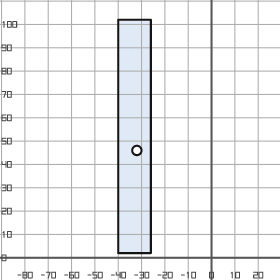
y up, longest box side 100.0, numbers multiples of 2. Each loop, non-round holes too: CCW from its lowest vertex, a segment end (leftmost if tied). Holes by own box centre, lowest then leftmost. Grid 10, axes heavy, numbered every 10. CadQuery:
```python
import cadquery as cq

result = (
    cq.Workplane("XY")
    .moveTo(-40.0, 2.0)
    .lineTo(-26.0, 2.0)
    .lineTo(-26.0, 102.0)
    .lineTo(-40.0, 102.0)
    .close()
    .moveTo(-32.0, 46.0)
    .circle(2.0)
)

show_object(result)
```